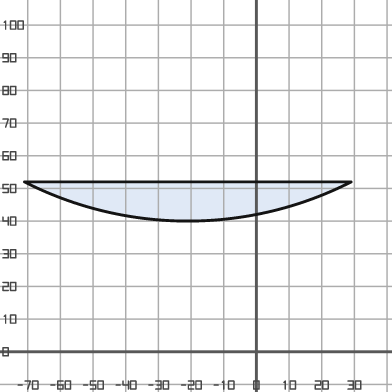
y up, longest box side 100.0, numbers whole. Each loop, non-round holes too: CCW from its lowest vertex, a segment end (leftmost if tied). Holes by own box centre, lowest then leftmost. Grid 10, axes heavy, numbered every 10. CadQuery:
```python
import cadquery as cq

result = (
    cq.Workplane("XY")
    .moveTo(-71.0, 52.0)
    .threePointArc((-21.0, 40.0), (29.0, 52.0))
    .close()
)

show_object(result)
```